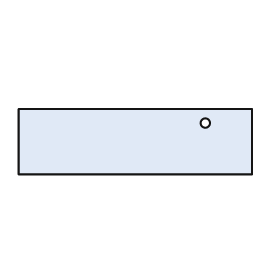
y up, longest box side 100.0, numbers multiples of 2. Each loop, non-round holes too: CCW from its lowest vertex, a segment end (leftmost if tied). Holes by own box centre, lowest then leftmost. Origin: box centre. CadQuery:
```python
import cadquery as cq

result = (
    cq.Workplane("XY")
    .moveTo(-50.0, -14.0)
    .lineTo(50.0, -14.0)
    .lineTo(50.0, 14.0)
    .lineTo(-50.0, 14.0)
    .close()
    .moveTo(30.0, 8.0)
    .circle(2.0)
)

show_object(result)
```